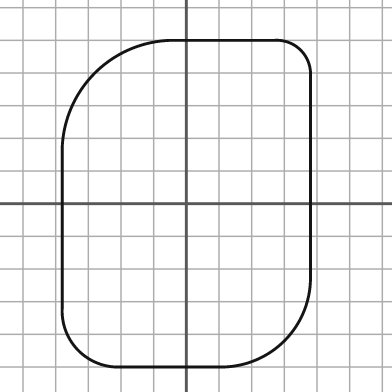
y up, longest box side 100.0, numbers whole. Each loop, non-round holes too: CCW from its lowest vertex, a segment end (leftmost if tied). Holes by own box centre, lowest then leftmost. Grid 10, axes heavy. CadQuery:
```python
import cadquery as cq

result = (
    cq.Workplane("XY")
    .moveTo(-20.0, -50.0)
    .lineTo(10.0, -50.0)
    .threePointArc((30.0, -42.0), (38.0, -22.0))
    .lineTo(38.0, 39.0)
    .threePointArc((35.0, 47.0), (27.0, 50.0))
    .lineTo(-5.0, 50.0)
    .threePointArc((-28.0, 40.0), (-38.0, 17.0))
    .lineTo(-38.0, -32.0)
    .threePointArc((-33.0, -45.0), (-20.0, -50.0))
    .close()
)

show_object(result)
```